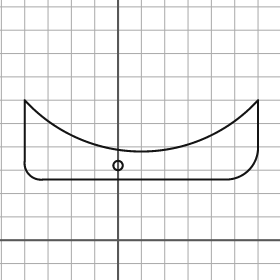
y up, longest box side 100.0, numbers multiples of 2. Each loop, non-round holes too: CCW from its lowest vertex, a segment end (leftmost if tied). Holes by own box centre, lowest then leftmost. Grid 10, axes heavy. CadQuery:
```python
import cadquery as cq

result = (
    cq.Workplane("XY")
    .moveTo(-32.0, 26.0)
    .lineTo(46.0, 26.0)
    .threePointArc((56.0, 30.0), (60.0, 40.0))
    .lineTo(60.0, 60.0)
    .threePointArc((10.0, 38.0), (-40.0, 60.0))
    .lineTo(-40.0, 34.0)
    .threePointArc((-38.0, 28.0), (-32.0, 26.0))
    .close()
    .moveTo(0.0, 32.0)
    .circle(2.0)
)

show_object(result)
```